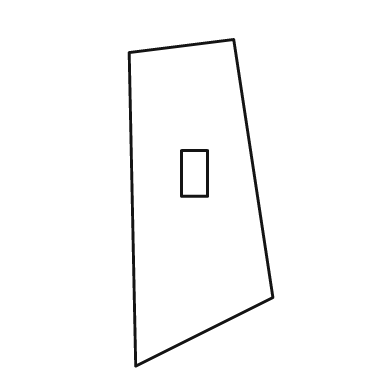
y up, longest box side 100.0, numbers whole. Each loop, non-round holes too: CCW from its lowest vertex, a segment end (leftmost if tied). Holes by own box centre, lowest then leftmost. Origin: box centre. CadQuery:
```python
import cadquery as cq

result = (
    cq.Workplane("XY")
    .moveTo(-20.0, -50.0)
    .lineTo(22.0, -29.0)
    .lineTo(10.0, 50.0)
    .lineTo(-22.0, 46.0)
    .close()
    .moveTo(-6.0, 2.0)
    .lineTo(2.0, 2.0)
    .lineTo(2.0, 16.0)
    .lineTo(-6.0, 16.0)
    .close()
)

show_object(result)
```